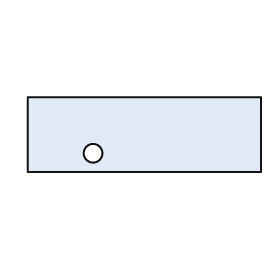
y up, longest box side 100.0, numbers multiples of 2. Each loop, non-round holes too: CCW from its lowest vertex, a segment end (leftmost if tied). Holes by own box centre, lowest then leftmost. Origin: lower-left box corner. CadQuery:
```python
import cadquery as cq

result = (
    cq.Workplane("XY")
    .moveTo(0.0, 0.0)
    .lineTo(100.0, 0.0)
    .lineTo(100.0, 32.0)
    .lineTo(0.0, 32.0)
    .close()
    .moveTo(28.0, 8.0)
    .circle(4.0)
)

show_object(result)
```